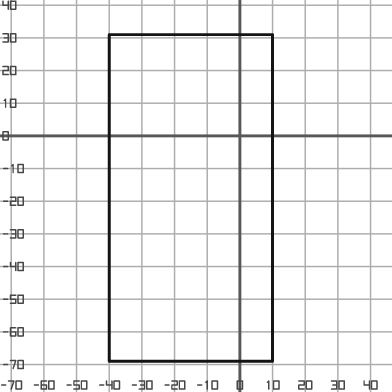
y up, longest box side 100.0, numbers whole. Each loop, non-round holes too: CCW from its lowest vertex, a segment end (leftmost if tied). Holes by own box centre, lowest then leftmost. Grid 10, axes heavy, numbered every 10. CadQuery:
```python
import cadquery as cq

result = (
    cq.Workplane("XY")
    .moveTo(-40.0, -69.0)
    .lineTo(10.0, -69.0)
    .lineTo(10.0, 31.0)
    .lineTo(-40.0, 31.0)
    .close()
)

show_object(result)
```